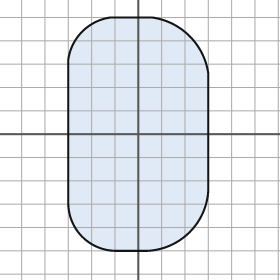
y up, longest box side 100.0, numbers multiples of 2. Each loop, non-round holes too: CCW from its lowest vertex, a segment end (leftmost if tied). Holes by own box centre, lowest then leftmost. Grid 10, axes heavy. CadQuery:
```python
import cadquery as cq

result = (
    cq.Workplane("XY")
    .moveTo(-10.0, -50.0)
    .lineTo(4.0, -50.0)
    .threePointArc((22.0, -42.0), (30.0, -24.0))
    .lineTo(30.0, 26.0)
    .threePointArc((22.0, 42.0), (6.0, 50.0))
    .lineTo(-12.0, 50.0)
    .threePointArc((-24.0, 44.0), (-30.0, 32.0))
    .lineTo(-30.0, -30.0)
    .threePointArc((-24.0, -44.0), (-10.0, -50.0))
    .close()
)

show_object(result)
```